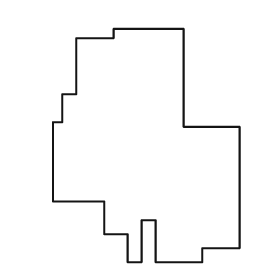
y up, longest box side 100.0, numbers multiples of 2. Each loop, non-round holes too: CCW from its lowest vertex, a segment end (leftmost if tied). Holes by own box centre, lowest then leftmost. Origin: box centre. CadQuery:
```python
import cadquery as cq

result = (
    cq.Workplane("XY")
    .moveTo(-8.0, -50.0)
    .lineTo(-2.0, -50.0)
    .lineTo(-2.0, -32.0)
    .lineTo(4.0, -32.0)
    .lineTo(4.0, -50.0)
    .lineTo(24.0, -50.0)
    .lineTo(24.0, -44.0)
    .lineTo(40.0, -44.0)
    .lineTo(40.0, 8.0)
    .lineTo(16.0, 8.0)
    .lineTo(16.0, 50.0)
    .lineTo(-14.0, 50.0)
    .lineTo(-14.0, 46.0)
    .lineTo(-30.0, 46.0)
    .lineTo(-30.0, 22.0)
    .lineTo(-36.0, 22.0)
    .lineTo(-36.0, 10.0)
    .lineTo(-40.0, 10.0)
    .lineTo(-40.0, -24.0)
    .lineTo(-18.0, -24.0)
    .lineTo(-18.0, -38.0)
    .lineTo(-8.0, -38.0)
    .close()
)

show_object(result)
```